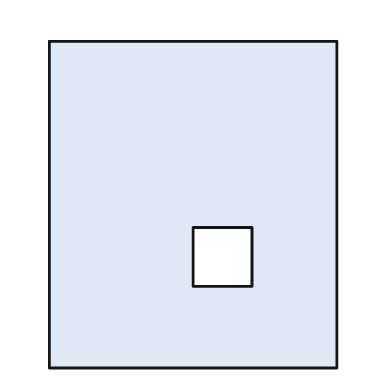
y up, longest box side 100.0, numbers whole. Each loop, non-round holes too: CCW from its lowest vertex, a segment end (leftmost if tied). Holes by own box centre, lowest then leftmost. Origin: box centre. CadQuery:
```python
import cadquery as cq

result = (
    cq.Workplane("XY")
    .moveTo(-44.0, -50.0)
    .lineTo(44.0, -50.0)
    .lineTo(44.0, 50.0)
    .lineTo(-44.0, 50.0)
    .close()
    .moveTo(0.0, -25.0)
    .lineTo(18.0, -25.0)
    .lineTo(18.0, -7.0)
    .lineTo(0.0, -7.0)
    .close()
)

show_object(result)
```